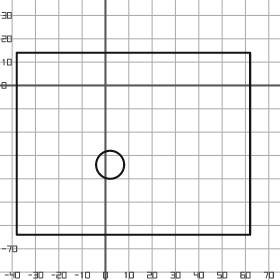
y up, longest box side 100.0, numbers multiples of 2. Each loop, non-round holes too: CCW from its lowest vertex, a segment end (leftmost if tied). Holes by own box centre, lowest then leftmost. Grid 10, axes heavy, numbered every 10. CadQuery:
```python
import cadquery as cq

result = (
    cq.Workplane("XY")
    .moveTo(-38.0, -64.0)
    .lineTo(62.0, -64.0)
    .lineTo(62.0, 14.0)
    .lineTo(-38.0, 14.0)
    .close()
    .moveTo(2.0, -34.0)
    .circle(6.0)
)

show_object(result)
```